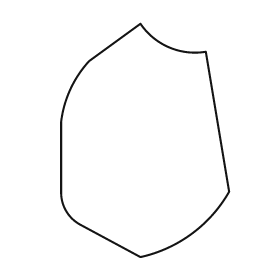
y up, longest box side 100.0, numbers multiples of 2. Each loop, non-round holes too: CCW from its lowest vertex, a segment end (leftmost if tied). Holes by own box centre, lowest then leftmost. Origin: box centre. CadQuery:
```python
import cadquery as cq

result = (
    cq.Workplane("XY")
    .moveTo(-2.0, -50.0)
    .threePointArc((20.0, -40.0), (36.0, -22.0))
    .lineTo(26.0, 38.0)
    .threePointArc((10.0, 40.0), (-2.0, 50.0))
    .lineTo(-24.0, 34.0)
    .threePointArc((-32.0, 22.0), (-36.0, 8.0))
    .lineTo(-36.0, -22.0)
    .threePointArc((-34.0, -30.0), (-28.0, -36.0))
    .close()
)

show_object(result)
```